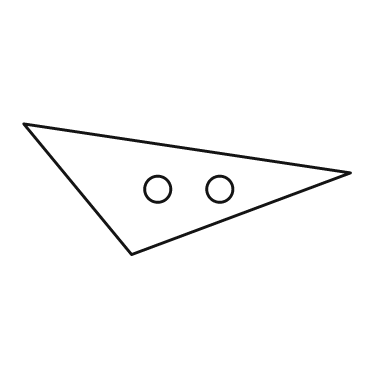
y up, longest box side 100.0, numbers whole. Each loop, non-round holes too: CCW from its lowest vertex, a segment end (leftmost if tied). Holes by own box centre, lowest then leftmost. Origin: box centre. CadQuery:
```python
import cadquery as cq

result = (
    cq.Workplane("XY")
    .moveTo(-17.0, -20.0)
    .lineTo(50.0, 5.0)
    .lineTo(-50.0, 20.0)
    .close()
    .moveTo(-9.0, 0.0)
    .circle(4.0)
    .moveTo(10.0, 0.0)
    .circle(4.0)
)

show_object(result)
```